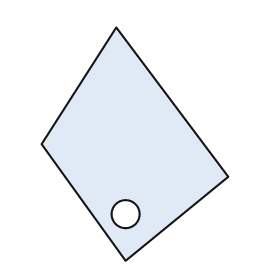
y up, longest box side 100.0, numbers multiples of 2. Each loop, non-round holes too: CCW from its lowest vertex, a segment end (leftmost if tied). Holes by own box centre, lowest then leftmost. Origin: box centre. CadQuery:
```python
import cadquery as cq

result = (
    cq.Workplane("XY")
    .moveTo(-4.0, -50.0)
    .lineTo(40.0, -14.0)
    .lineTo(-8.0, 50.0)
    .lineTo(-40.0, 0.0)
    .close()
    .moveTo(-4.0, -30.0)
    .circle(6.0)
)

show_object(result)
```